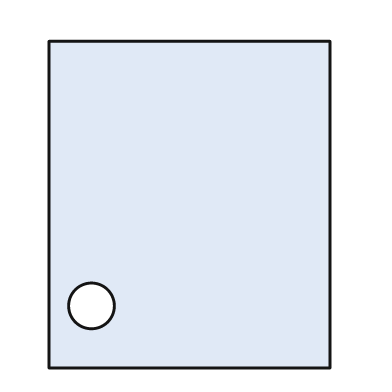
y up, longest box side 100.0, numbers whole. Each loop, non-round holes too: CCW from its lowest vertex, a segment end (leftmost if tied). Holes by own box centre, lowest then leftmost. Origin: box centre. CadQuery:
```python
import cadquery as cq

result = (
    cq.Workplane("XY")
    .moveTo(-43.0, -50.0)
    .lineTo(43.0, -50.0)
    .lineTo(43.0, 50.0)
    .lineTo(-43.0, 50.0)
    .close()
    .moveTo(-30.0, -31.0)
    .circle(7.0)
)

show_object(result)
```